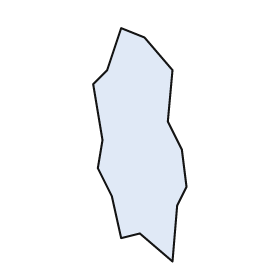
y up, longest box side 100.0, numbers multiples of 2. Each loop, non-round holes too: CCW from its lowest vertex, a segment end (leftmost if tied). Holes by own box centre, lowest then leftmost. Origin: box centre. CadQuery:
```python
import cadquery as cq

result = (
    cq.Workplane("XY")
    .moveTo(14.0, -50.0)
    .lineTo(16.0, -26.0)
    .lineTo(20.0, -18.0)
    .lineTo(18.0, -2.0)
    .lineTo(12.0, 10.0)
    .lineTo(14.0, 32.0)
    .lineTo(2.0, 46.0)
    .lineTo(-8.0, 50.0)
    .lineTo(-14.0, 32.0)
    .lineTo(-20.0, 26.0)
    .lineTo(-16.0, 2.0)
    .lineTo(-18.0, -10.0)
    .lineTo(-12.0, -22.0)
    .lineTo(-8.0, -40.0)
    .lineTo(0.0, -38.0)
    .close()
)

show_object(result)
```